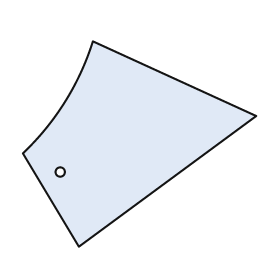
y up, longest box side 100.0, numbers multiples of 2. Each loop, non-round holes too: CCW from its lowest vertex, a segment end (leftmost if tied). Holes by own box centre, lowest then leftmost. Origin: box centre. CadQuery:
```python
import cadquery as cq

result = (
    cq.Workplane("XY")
    .moveTo(-26.0, -44.0)
    .lineTo(50.0, 12.0)
    .lineTo(-20.0, 44.0)
    .threePointArc((-32.0, 18.0), (-50.0, -4.0))
    .close()
    .moveTo(-34.0, -12.0)
    .circle(2.0)
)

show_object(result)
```